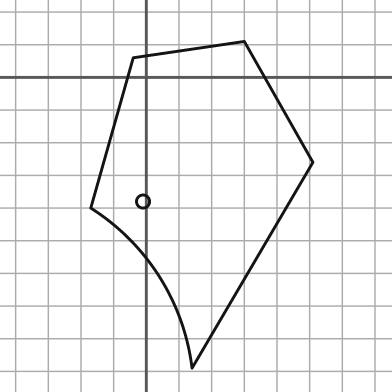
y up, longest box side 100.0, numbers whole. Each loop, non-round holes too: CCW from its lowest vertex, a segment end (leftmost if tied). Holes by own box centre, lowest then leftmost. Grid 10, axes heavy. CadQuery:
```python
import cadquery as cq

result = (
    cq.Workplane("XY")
    .moveTo(14.0, -89.0)
    .lineTo(51.0, -26.0)
    .lineTo(30.0, 11.0)
    .lineTo(-4.0, 6.0)
    .lineTo(-17.0, -40.0)
    .threePointArc((4.0, -61.0), (14.0, -89.0))
    .close()
    .moveTo(-1.0, -38.0)
    .circle(2.0)
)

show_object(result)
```